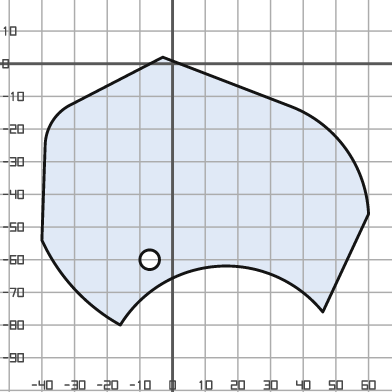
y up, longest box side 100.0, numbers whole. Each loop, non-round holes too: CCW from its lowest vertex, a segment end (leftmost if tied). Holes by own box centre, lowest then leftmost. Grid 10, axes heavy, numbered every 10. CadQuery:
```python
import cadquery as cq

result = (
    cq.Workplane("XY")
    .moveTo(-16.0, -80.0)
    .threePointArc((14.0, -62.0), (46.0, -76.0))
    .lineTo(60.0, -46.0)
    .threePointArc((53.0, -26.0), (36.0, -13.0))
    .lineTo(-3.0, 2.0)
    .lineTo(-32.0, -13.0)
    .threePointArc((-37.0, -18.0), (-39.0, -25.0))
    .lineTo(-40.0, -54.0)
    .threePointArc((-30.0, -69.0), (-16.0, -80.0))
    .close()
    .moveTo(-7.0, -60.0)
    .circle(3.0)
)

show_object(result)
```